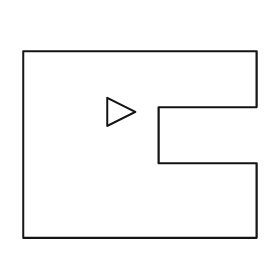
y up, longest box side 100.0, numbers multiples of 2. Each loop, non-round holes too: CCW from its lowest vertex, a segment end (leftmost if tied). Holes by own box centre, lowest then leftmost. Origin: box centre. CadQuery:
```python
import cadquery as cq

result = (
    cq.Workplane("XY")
    .moveTo(-50.0, -40.0)
    .lineTo(50.0, -40.0)
    .lineTo(50.0, -8.0)
    .lineTo(8.0, -8.0)
    .lineTo(8.0, 16.0)
    .lineTo(50.0, 16.0)
    .lineTo(50.0, 40.0)
    .lineTo(-50.0, 40.0)
    .close()
    .moveTo(-14.0, 8.0)
    .lineTo(-2.0, 14.0)
    .lineTo(-14.0, 20.0)
    .close()
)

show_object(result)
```